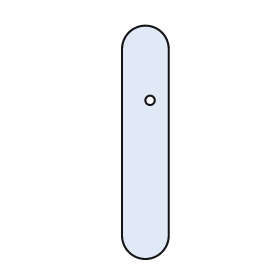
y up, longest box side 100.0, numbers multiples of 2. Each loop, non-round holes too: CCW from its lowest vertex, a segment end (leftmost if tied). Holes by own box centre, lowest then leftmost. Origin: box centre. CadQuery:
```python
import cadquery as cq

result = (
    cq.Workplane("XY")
    .moveTo(-10.0, -40.0)
    .threePointArc((0.0, -50.0), (10.0, -40.0))
    .lineTo(10.0, 40.0)
    .threePointArc((0.0, 50.0), (-10.0, 40.0))
    .close()
    .moveTo(2.0, 18.0)
    .circle(2.0)
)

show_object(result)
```